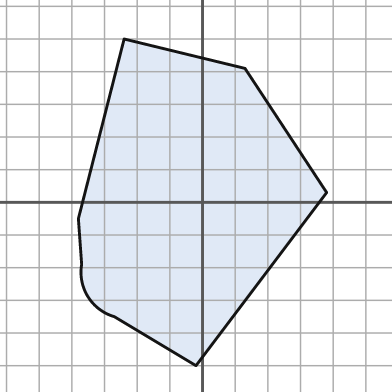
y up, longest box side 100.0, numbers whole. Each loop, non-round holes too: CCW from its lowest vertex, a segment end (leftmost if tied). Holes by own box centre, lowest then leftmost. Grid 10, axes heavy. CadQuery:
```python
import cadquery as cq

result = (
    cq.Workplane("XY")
    .moveTo(-2.0, -50.0)
    .lineTo(38.0, 3.0)
    .lineTo(13.0, 41.0)
    .lineTo(-24.0, 50.0)
    .lineTo(-38.0, -5.0)
    .lineTo(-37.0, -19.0)
    .threePointArc((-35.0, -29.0), (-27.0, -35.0))
    .close()
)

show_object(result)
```